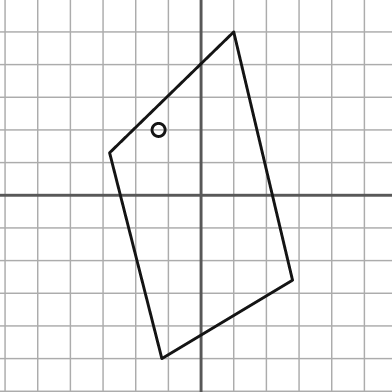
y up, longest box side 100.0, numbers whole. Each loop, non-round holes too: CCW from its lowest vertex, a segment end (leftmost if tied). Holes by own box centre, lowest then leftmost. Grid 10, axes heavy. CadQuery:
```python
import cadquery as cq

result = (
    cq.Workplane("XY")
    .moveTo(-12.0, -50.0)
    .lineTo(28.0, -26.0)
    .lineTo(10.0, 50.0)
    .lineTo(-28.0, 13.0)
    .close()
    .moveTo(-13.0, 20.0)
    .circle(2.0)
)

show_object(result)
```